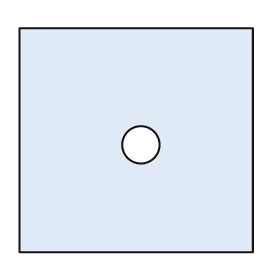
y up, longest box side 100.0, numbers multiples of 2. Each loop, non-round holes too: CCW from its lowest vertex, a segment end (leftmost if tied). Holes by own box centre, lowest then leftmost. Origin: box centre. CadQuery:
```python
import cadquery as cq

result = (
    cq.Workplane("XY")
    .moveTo(-50.0, -48.0)
    .lineTo(50.0, -48.0)
    .lineTo(50.0, 48.0)
    .lineTo(-50.0, 48.0)
    .close()
    .moveTo(2.0, -2.0)
    .circle(8.0)
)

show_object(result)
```